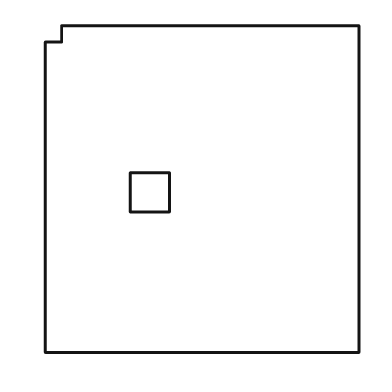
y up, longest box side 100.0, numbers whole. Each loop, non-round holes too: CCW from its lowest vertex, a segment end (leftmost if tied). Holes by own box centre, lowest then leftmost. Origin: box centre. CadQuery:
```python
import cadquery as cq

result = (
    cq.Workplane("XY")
    .moveTo(-48.0, -50.0)
    .lineTo(48.0, -50.0)
    .lineTo(48.0, 50.0)
    .lineTo(-43.0, 50.0)
    .lineTo(-43.0, 45.0)
    .lineTo(-48.0, 45.0)
    .close()
    .moveTo(-22.0, -7.0)
    .lineTo(-10.0, -7.0)
    .lineTo(-10.0, 5.0)
    .lineTo(-22.0, 5.0)
    .close()
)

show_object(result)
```